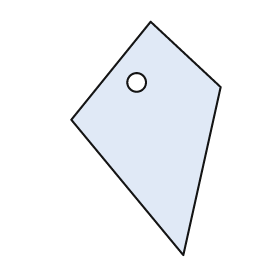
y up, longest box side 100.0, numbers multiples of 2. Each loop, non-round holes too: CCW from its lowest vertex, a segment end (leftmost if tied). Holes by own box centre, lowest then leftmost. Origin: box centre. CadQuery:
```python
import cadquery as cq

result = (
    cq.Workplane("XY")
    .moveTo(16.0, -50.0)
    .lineTo(32.0, 22.0)
    .lineTo(2.0, 50.0)
    .lineTo(-32.0, 8.0)
    .close()
    .moveTo(-4.0, 24.0)
    .circle(4.0)
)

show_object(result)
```